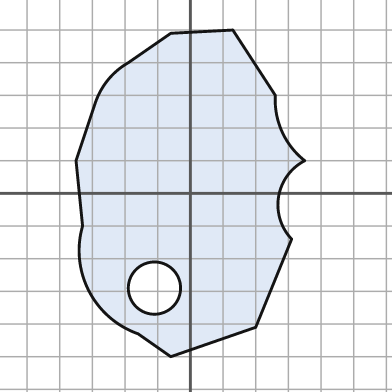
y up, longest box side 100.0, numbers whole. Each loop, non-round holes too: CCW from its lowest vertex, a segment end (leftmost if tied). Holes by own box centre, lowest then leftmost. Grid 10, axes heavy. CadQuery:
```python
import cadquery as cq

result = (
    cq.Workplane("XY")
    .moveTo(-6.0, -50.0)
    .lineTo(20.0, -41.0)
    .lineTo(31.0, -14.0)
    .threePointArc((27.0, -1.0), (35.0, 10.0))
    .threePointArc((28.0, 19.0), (26.0, 30.0))
    .lineTo(13.0, 50.0)
    .lineTo(-6.0, 49.0)
    .lineTo(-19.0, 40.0)
    .threePointArc((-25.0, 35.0), (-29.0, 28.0))
    .lineTo(-35.0, 10.0)
    .lineTo(-33.0, -10.0)
    .threePointArc((-31.0, -30.0), (-16.0, -43.0))
    .close()
    .moveTo(-11.0, -29.0)
    .circle(8.0)
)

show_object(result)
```